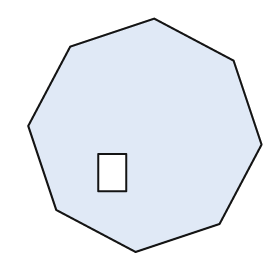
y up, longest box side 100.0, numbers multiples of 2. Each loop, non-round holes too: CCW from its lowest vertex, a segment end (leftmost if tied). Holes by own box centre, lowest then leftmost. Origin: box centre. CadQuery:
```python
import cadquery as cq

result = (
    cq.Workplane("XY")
    .moveTo(-4.0, -50.0)
    .lineTo(32.0, -38.0)
    .lineTo(50.0, -4.0)
    .lineTo(38.0, 32.0)
    .lineTo(4.0, 50.0)
    .lineTo(-32.0, 38.0)
    .lineTo(-50.0, 4.0)
    .lineTo(-38.0, -32.0)
    .close()
    .moveTo(-20.0, -24.0)
    .lineTo(-8.0, -24.0)
    .lineTo(-8.0, -8.0)
    .lineTo(-20.0, -8.0)
    .close()
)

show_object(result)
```